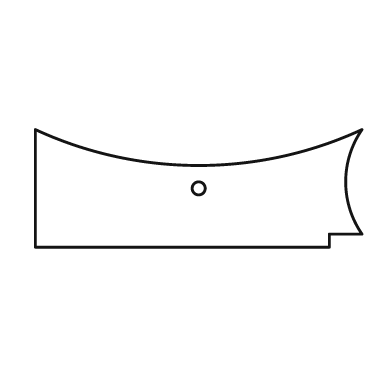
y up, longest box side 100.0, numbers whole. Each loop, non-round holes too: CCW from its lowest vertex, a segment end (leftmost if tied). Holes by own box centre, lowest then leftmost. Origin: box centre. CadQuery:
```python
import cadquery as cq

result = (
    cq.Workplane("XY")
    .moveTo(-50.0, -18.0)
    .lineTo(40.0, -18.0)
    .lineTo(40.0, -14.0)
    .lineTo(50.0, -14.0)
    .threePointArc((45.0, 2.0), (50.0, 18.0))
    .threePointArc((0.0, 7.0), (-50.0, 18.0))
    .close()
    .moveTo(0.0, 0.0)
    .circle(2.0)
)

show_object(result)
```